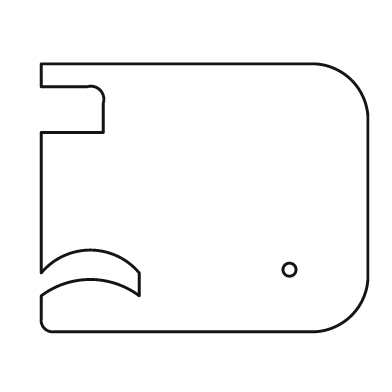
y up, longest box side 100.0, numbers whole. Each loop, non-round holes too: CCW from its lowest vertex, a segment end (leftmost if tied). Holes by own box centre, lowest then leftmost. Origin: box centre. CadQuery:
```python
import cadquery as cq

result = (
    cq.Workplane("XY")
    .moveTo(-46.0, -41.0)
    .lineTo(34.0, -41.0)
    .threePointArc((45.0, -36.0), (50.0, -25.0))
    .lineTo(50.0, 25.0)
    .threePointArc((45.0, 36.0), (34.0, 41.0))
    .lineTo(-50.0, 41.0)
    .lineTo(-50.0, 34.0)
    .lineTo(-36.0, 34.0)
    .threePointArc((-32.0, 33.0), (-31.0, 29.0))
    .lineTo(-31.0, 20.0)
    .lineTo(-50.0, 20.0)
    .lineTo(-50.0, -23.0)
    .threePointArc((-35.0, -16.0), (-20.0, -23.0))
    .lineTo(-20.0, -30.0)
    .threePointArc((-35.0, -25.0), (-50.0, -30.0))
    .lineTo(-50.0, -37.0)
    .threePointArc((-49.0, -40.0), (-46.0, -41.0))
    .close()
    .moveTo(26.0, -22.0)
    .circle(2.0)
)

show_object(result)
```